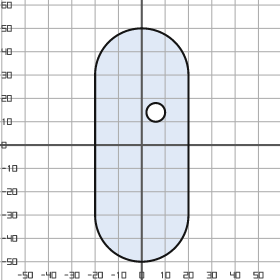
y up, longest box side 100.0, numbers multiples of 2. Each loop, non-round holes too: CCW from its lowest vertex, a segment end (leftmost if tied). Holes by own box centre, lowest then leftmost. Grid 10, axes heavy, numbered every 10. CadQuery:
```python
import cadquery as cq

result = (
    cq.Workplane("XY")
    .moveTo(-20.0, -30.0)
    .threePointArc((0.0, -50.0), (20.0, -30.0))
    .lineTo(20.0, 30.0)
    .threePointArc((0.0, 50.0), (-20.0, 30.0))
    .close()
    .moveTo(6.0, 14.0)
    .circle(4.0)
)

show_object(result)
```